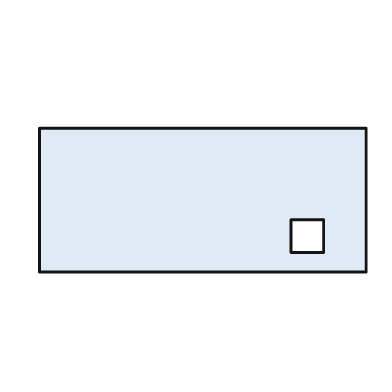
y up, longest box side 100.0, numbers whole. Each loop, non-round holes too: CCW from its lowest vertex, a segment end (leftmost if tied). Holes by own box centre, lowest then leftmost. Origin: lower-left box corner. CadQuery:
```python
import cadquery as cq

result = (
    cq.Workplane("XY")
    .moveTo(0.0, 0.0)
    .lineTo(100.0, 0.0)
    .lineTo(100.0, 44.0)
    .lineTo(0.0, 44.0)
    .close()
    .moveTo(77.0, 6.0)
    .lineTo(87.0, 6.0)
    .lineTo(87.0, 16.0)
    .lineTo(77.0, 16.0)
    .close()
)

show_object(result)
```